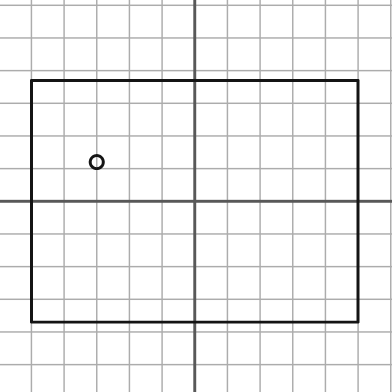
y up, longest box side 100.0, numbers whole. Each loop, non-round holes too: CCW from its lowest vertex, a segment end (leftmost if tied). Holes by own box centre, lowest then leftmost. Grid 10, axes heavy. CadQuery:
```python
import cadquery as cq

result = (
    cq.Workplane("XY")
    .moveTo(-50.0, -37.0)
    .lineTo(50.0, -37.0)
    .lineTo(50.0, 37.0)
    .lineTo(-50.0, 37.0)
    .close()
    .moveTo(-30.0, 12.0)
    .circle(2.0)
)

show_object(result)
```